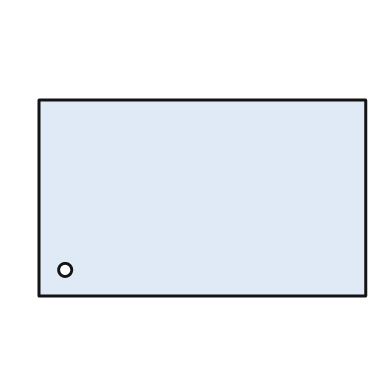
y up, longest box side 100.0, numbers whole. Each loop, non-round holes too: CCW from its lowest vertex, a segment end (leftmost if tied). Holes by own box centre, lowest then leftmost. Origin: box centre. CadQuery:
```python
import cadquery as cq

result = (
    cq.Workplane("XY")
    .moveTo(-50.0, -30.0)
    .lineTo(50.0, -30.0)
    .lineTo(50.0, 30.0)
    .lineTo(-50.0, 30.0)
    .close()
    .moveTo(-42.0, -22.0)
    .circle(2.0)
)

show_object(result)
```